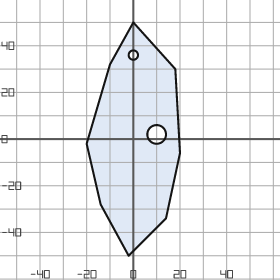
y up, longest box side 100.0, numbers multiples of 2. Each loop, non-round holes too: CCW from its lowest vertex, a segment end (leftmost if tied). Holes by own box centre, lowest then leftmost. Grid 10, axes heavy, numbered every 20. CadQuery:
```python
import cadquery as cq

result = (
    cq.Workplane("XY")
    .moveTo(-2.0, -50.0)
    .lineTo(14.0, -34.0)
    .lineTo(20.0, -6.0)
    .lineTo(18.0, 30.0)
    .lineTo(0.0, 50.0)
    .lineTo(-10.0, 32.0)
    .lineTo(-20.0, -2.0)
    .lineTo(-14.0, -28.0)
    .close()
    .moveTo(10.0, 2.0)
    .circle(4.0)
    .moveTo(0.0, 36.0)
    .circle(2.0)
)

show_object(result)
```